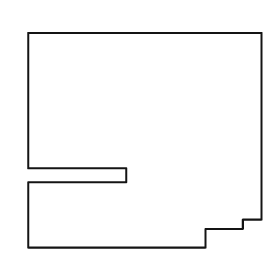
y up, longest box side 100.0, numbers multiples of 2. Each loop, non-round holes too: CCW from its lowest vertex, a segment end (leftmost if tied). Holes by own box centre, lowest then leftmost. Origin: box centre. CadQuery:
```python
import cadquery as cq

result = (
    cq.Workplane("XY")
    .moveTo(-50.0, -46.0)
    .lineTo(26.0, -46.0)
    .lineTo(26.0, -38.0)
    .lineTo(42.0, -38.0)
    .lineTo(42.0, -34.0)
    .lineTo(50.0, -34.0)
    .lineTo(50.0, 46.0)
    .lineTo(-50.0, 46.0)
    .lineTo(-50.0, -12.0)
    .lineTo(-8.0, -12.0)
    .lineTo(-8.0, -18.0)
    .lineTo(-50.0, -18.0)
    .close()
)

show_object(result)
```